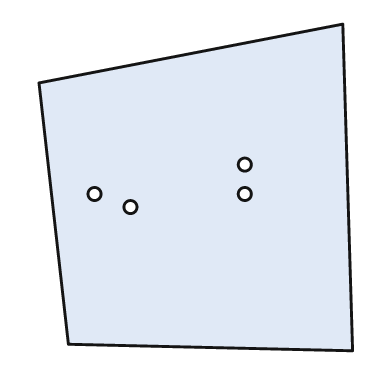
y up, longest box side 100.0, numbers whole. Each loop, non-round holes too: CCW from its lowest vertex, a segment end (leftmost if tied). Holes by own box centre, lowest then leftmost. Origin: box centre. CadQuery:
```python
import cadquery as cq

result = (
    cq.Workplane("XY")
    .moveTo(48.0, -50.0)
    .lineTo(45.0, 50.0)
    .lineTo(-48.0, 32.0)
    .lineTo(-39.0, -48.0)
    .close()
    .moveTo(-20.0, -6.0)
    .circle(2.0)
    .moveTo(-31.0, -2.0)
    .circle(2.0)
    .moveTo(15.0, -2.0)
    .circle(2.0)
    .moveTo(15.0, 7.0)
    .circle(2.0)
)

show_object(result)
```